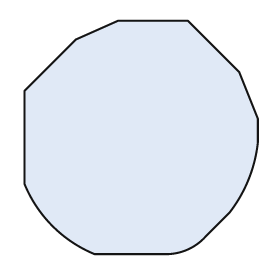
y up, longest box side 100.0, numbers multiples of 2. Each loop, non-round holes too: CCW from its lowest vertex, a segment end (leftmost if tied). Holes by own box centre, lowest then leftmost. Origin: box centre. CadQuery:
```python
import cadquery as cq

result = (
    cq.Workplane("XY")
    .moveTo(-20.0, -50.0)
    .lineTo(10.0, -50.0)
    .threePointArc((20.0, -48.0), (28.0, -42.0))
    .lineTo(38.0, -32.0)
    .threePointArc((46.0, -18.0), (50.0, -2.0))
    .lineTo(50.0, 8.0)
    .lineTo(42.0, 28.0)
    .lineTo(20.0, 50.0)
    .lineTo(-10.0, 50.0)
    .lineTo(-28.0, 42.0)
    .lineTo(-50.0, 20.0)
    .lineTo(-50.0, -20.0)
    .threePointArc((-38.0, -38.0), (-20.0, -50.0))
    .close()
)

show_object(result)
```